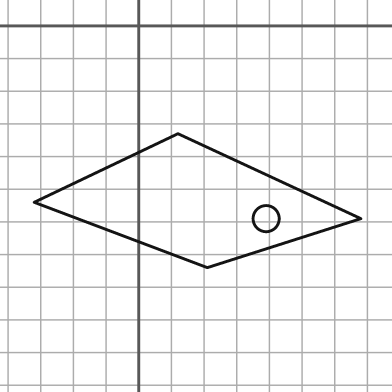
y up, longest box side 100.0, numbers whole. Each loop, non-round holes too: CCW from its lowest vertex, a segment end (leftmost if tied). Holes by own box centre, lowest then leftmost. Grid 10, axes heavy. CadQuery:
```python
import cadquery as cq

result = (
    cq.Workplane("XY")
    .moveTo(21.0, -74.0)
    .lineTo(68.0, -59.0)
    .lineTo(12.0, -33.0)
    .lineTo(-32.0, -54.0)
    .close()
    .moveTo(39.0, -59.0)
    .circle(4.0)
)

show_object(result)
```